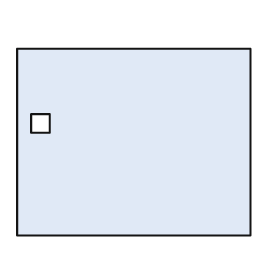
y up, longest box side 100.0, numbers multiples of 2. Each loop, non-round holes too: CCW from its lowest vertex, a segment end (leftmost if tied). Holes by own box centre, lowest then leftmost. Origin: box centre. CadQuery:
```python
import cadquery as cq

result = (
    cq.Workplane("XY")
    .moveTo(-50.0, -40.0)
    .lineTo(50.0, -40.0)
    .lineTo(50.0, 40.0)
    .lineTo(-50.0, 40.0)
    .close()
    .moveTo(-44.0, 4.0)
    .lineTo(-36.0, 4.0)
    .lineTo(-36.0, 12.0)
    .lineTo(-44.0, 12.0)
    .close()
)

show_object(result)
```